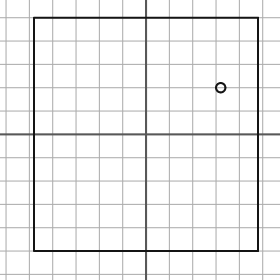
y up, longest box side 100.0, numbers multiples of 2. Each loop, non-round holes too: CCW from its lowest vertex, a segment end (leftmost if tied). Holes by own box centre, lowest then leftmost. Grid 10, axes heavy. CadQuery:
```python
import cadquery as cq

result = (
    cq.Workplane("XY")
    .moveTo(-48.0, -50.0)
    .lineTo(48.0, -50.0)
    .lineTo(48.0, 50.0)
    .lineTo(-48.0, 50.0)
    .close()
    .moveTo(32.0, 20.0)
    .circle(2.0)
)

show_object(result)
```